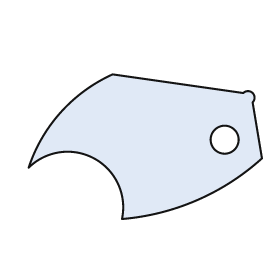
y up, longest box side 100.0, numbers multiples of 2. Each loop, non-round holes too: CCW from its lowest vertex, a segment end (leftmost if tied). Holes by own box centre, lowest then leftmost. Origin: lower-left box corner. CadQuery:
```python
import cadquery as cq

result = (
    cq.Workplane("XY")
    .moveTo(40.0, 0.0)
    .threePointArc((72.0, 8.0), (100.0, 26.0))
    .lineTo(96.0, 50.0)
    .threePointArc((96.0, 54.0), (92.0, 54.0))
    .lineTo(36.0, 62.0)
    .threePointArc((14.0, 46.0), (0.0, 22.0))
    .threePointArc((28.0, 26.0), (40.0, 0.0))
    .close()
    .moveTo(84.0, 34.0)
    .circle(6.0)
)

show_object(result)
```